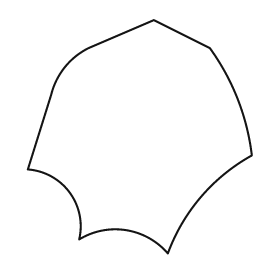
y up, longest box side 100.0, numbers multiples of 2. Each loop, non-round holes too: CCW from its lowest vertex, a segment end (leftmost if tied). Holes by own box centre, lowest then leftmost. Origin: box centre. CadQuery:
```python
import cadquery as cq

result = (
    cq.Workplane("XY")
    .moveTo(12.0, -50.0)
    .threePointArc((26.0, -26.0), (48.0, -8.0))
    .threePointArc((42.0, 16.0), (30.0, 38.0))
    .lineTo(6.0, 50.0)
    .lineTo(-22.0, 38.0)
    .threePointArc((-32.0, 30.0), (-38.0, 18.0))
    .lineTo(-48.0, -14.0)
    .threePointArc((-30.0, -24.0), (-26.0, -44.0))
    .threePointArc((-6.0, -40.0), (12.0, -50.0))
    .close()
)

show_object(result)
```